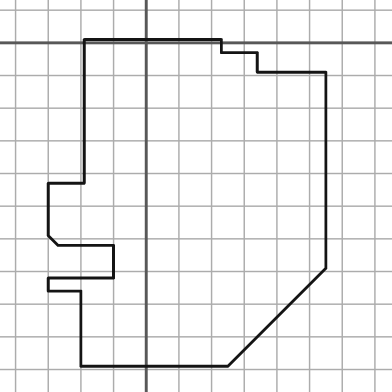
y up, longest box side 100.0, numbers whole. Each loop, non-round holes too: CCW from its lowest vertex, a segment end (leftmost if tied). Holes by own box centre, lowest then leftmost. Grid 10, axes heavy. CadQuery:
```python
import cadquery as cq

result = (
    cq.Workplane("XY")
    .moveTo(-20.0, -99.0)
    .lineTo(25.0, -99.0)
    .lineTo(55.0, -69.0)
    .lineTo(55.0, -9.0)
    .lineTo(34.0, -9.0)
    .lineTo(34.0, -3.0)
    .lineTo(23.0, -3.0)
    .lineTo(23.0, 1.0)
    .lineTo(-19.0, 1.0)
    .lineTo(-19.0, -43.0)
    .lineTo(-30.0, -43.0)
    .lineTo(-30.0, -59.0)
    .lineTo(-27.0, -62.0)
    .lineTo(-10.0, -62.0)
    .lineTo(-10.0, -72.0)
    .lineTo(-30.0, -72.0)
    .lineTo(-30.0, -76.0)
    .lineTo(-20.0, -76.0)
    .close()
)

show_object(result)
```